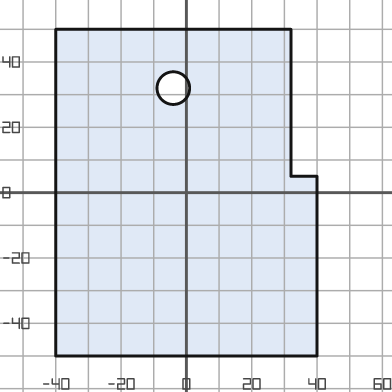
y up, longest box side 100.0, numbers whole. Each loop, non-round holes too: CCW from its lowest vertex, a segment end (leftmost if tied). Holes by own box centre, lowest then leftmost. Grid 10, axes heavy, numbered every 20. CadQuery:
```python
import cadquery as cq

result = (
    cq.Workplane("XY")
    .moveTo(-40.0, -50.0)
    .lineTo(40.0, -50.0)
    .lineTo(40.0, 5.0)
    .lineTo(32.0, 5.0)
    .lineTo(32.0, 50.0)
    .lineTo(-40.0, 50.0)
    .close()
    .moveTo(-4.0, 32.0)
    .circle(5.0)
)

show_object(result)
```